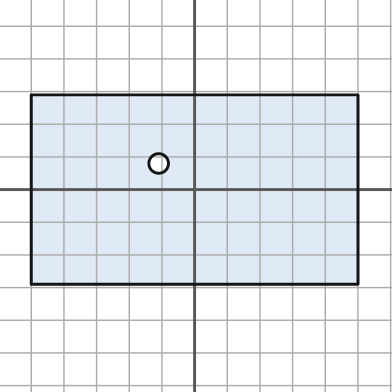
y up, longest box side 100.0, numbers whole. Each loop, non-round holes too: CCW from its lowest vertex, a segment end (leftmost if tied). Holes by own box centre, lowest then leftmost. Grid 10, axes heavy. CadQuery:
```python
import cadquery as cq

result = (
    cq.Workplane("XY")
    .moveTo(-50.0, -29.0)
    .lineTo(50.0, -29.0)
    .lineTo(50.0, 29.0)
    .lineTo(-50.0, 29.0)
    .close()
    .moveTo(-11.0, 8.0)
    .circle(3.0)
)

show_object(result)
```